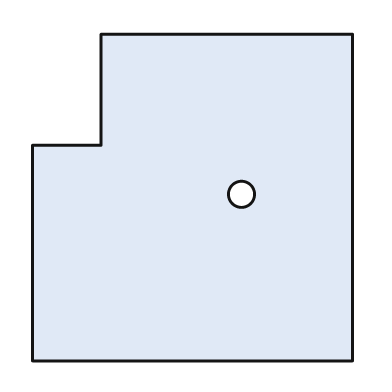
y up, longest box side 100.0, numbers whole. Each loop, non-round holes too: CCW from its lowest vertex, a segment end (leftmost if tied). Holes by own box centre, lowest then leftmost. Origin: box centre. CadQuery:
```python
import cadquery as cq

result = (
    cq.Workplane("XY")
    .moveTo(-49.0, -50.0)
    .lineTo(49.0, -50.0)
    .lineTo(49.0, 50.0)
    .lineTo(-28.0, 50.0)
    .lineTo(-28.0, 16.0)
    .lineTo(-49.0, 16.0)
    .close()
    .moveTo(15.0, 1.0)
    .circle(4.0)
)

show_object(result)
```